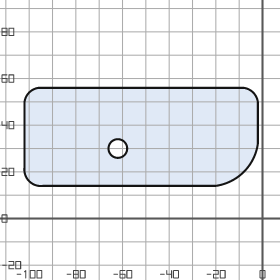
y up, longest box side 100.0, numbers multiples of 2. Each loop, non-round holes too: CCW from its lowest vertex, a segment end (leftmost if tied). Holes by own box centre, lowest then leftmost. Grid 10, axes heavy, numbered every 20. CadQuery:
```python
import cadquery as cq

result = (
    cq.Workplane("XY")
    .moveTo(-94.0, 14.0)
    .lineTo(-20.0, 14.0)
    .threePointArc((-8.0, 20.0), (-2.0, 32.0))
    .lineTo(-2.0, 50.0)
    .threePointArc((-4.0, 54.0), (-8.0, 56.0))
    .lineTo(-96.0, 56.0)
    .threePointArc((-100.0, 54.0), (-102.0, 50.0))
    .lineTo(-102.0, 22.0)
    .threePointArc((-100.0, 16.0), (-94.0, 14.0))
    .close()
    .moveTo(-62.0, 30.0)
    .circle(4.0)
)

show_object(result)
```